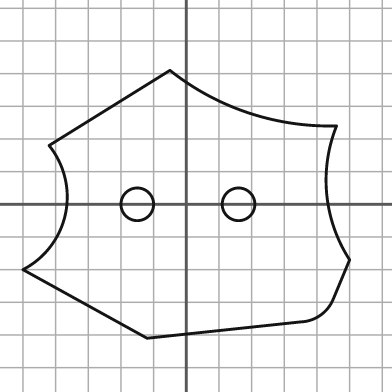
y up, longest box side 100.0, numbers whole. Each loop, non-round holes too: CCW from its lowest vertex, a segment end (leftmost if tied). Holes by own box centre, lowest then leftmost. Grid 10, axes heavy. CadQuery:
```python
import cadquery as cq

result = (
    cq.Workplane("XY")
    .moveTo(-12.0, -41.0)
    .lineTo(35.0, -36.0)
    .threePointArc((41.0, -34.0), (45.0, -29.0))
    .lineTo(50.0, -17.0)
    .threePointArc((43.0, 3.0), (46.0, 24.0))
    .threePointArc((19.0, 28.0), (-5.0, 41.0))
    .lineTo(-42.0, 18.0)
    .threePointArc((-37.0, -3.0), (-50.0, -20.0))
    .close()
    .moveTo(-15.0, 0.0)
    .circle(5.0)
    .moveTo(16.0, 0.0)
    .circle(5.0)
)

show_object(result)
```